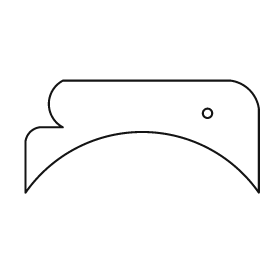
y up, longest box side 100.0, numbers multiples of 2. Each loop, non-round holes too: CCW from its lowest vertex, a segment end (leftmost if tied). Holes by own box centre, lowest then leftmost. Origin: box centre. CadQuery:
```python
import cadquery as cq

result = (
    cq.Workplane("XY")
    .moveTo(-50.0, -24.0)
    .threePointArc((0.0, 2.0), (50.0, -24.0))
    .lineTo(50.0, 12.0)
    .threePointArc((46.0, 20.0), (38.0, 24.0))
    .lineTo(-34.0, 24.0)
    .threePointArc((-40.0, 14.0), (-34.0, 4.0))
    .lineTo(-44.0, 4.0)
    .threePointArc((-48.0, 2.0), (-50.0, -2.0))
    .close()
    .moveTo(28.0, 10.0)
    .circle(2.0)
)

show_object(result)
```